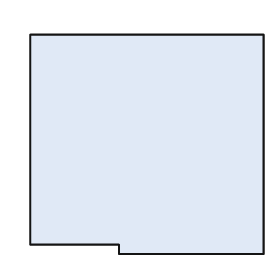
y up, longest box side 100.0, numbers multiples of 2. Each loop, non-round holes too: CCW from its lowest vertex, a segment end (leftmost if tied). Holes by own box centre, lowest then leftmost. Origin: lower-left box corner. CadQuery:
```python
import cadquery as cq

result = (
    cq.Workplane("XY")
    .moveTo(38.0, 0.0)
    .lineTo(100.0, 0.0)
    .lineTo(100.0, 94.0)
    .lineTo(0.0, 94.0)
    .lineTo(0.0, 4.0)
    .lineTo(38.0, 4.0)
    .close()
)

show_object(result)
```